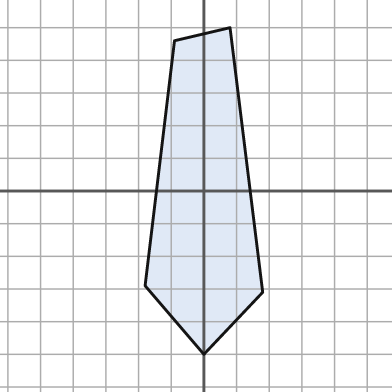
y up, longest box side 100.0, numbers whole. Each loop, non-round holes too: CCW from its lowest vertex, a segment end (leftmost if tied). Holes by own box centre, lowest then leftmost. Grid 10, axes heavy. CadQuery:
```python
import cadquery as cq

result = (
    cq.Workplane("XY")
    .moveTo(0.0, -50.0)
    .lineTo(18.0, -31.0)
    .lineTo(8.0, 50.0)
    .lineTo(-9.0, 46.0)
    .lineTo(-18.0, -29.0)
    .close()
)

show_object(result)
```